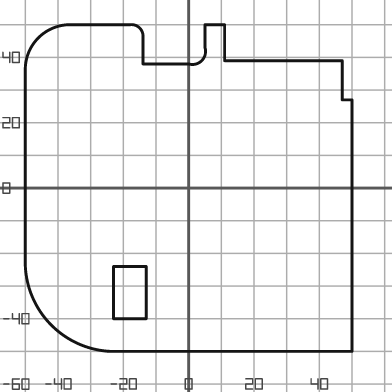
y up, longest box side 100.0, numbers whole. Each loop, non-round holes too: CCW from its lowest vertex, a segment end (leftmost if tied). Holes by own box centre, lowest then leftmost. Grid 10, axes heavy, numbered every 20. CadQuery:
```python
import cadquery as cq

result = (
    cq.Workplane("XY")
    .moveTo(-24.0, -50.0)
    .lineTo(50.0, -50.0)
    .lineTo(50.0, 27.0)
    .lineTo(47.0, 27.0)
    .lineTo(47.0, 39.0)
    .lineTo(11.0, 39.0)
    .lineTo(11.0, 50.0)
    .lineTo(5.0, 50.0)
    .lineTo(5.0, 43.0)
    .threePointArc((4.0, 39.0), (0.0, 38.0))
    .lineTo(-14.0, 38.0)
    .lineTo(-14.0, 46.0)
    .threePointArc((-15.0, 49.0), (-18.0, 50.0))
    .lineTo(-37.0, 50.0)
    .threePointArc((-46.0, 46.0), (-50.0, 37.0))
    .lineTo(-50.0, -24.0)
    .threePointArc((-42.0, -42.0), (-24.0, -50.0))
    .close()
    .moveTo(-23.0, -40.0)
    .lineTo(-13.0, -40.0)
    .lineTo(-13.0, -24.0)
    .lineTo(-23.0, -24.0)
    .close()
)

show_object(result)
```